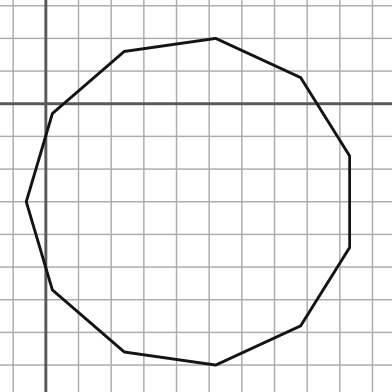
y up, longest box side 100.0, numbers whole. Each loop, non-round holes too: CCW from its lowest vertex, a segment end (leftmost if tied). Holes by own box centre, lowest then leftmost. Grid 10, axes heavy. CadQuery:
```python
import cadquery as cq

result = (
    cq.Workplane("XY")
    .moveTo(52.0, -80.0)
    .lineTo(78.0, -68.0)
    .lineTo(93.0, -44.0)
    .lineTo(93.0, -16.0)
    .lineTo(78.0, 8.0)
    .lineTo(52.0, 20.0)
    .lineTo(24.0, 16.0)
    .lineTo(2.0, -3.0)
    .lineTo(-6.0, -30.0)
    .lineTo(2.0, -57.0)
    .lineTo(24.0, -76.0)
    .close()
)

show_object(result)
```